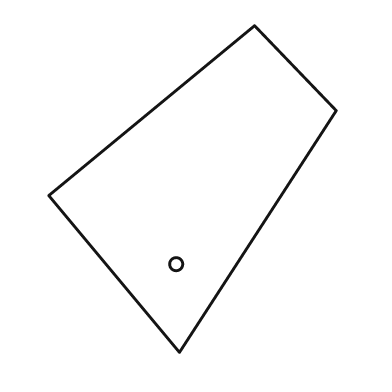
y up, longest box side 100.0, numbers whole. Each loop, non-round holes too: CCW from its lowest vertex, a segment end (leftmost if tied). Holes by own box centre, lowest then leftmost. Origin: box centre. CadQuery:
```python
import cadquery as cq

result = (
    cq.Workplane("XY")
    .moveTo(-4.0, -50.0)
    .lineTo(44.0, 24.0)
    .lineTo(19.0, 50.0)
    .lineTo(-44.0, -2.0)
    .close()
    .moveTo(-5.0, -23.0)
    .circle(2.0)
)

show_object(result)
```